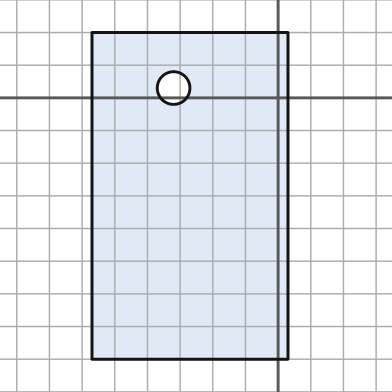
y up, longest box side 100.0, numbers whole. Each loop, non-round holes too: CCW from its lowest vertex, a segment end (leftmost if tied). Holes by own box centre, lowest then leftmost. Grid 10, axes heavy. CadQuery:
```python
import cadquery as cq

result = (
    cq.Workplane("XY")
    .moveTo(-57.0, -80.0)
    .lineTo(3.0, -80.0)
    .lineTo(3.0, 20.0)
    .lineTo(-57.0, 20.0)
    .close()
    .moveTo(-32.0, 3.0)
    .circle(5.0)
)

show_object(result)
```